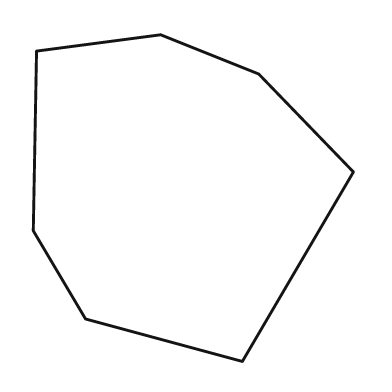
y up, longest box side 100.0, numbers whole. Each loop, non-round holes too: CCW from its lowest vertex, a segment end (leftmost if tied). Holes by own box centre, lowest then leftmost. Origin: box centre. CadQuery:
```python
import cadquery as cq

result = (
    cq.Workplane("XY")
    .moveTo(15.0, -50.0)
    .lineTo(49.0, 8.0)
    .lineTo(20.0, 38.0)
    .lineTo(-10.0, 50.0)
    .lineTo(-48.0, 45.0)
    .lineTo(-49.0, -10.0)
    .lineTo(-33.0, -37.0)
    .close()
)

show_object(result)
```